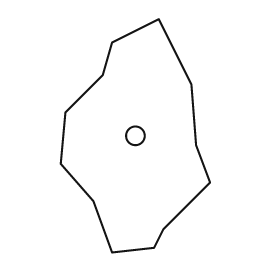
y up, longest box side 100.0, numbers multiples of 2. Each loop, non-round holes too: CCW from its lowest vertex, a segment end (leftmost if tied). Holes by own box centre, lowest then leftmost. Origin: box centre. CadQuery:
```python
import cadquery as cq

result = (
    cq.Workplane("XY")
    .moveTo(-10.0, -50.0)
    .lineTo(8.0, -48.0)
    .lineTo(12.0, -40.0)
    .lineTo(32.0, -20.0)
    .lineTo(26.0, -4.0)
    .lineTo(24.0, 22.0)
    .lineTo(10.0, 50.0)
    .lineTo(-10.0, 40.0)
    .lineTo(-14.0, 26.0)
    .lineTo(-30.0, 10.0)
    .lineTo(-32.0, -12.0)
    .lineTo(-18.0, -28.0)
    .close()
    .moveTo(0.0, 0.0)
    .circle(4.0)
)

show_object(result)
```